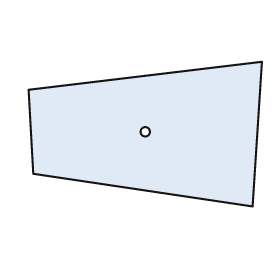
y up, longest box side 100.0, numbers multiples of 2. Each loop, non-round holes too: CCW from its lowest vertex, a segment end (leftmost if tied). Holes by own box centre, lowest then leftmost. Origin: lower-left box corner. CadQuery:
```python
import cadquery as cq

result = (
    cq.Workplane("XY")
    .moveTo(96.0, 0.0)
    .lineTo(100.0, 62.0)
    .lineTo(0.0, 50.0)
    .lineTo(2.0, 14.0)
    .close()
    .moveTo(50.0, 32.0)
    .circle(2.0)
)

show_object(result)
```